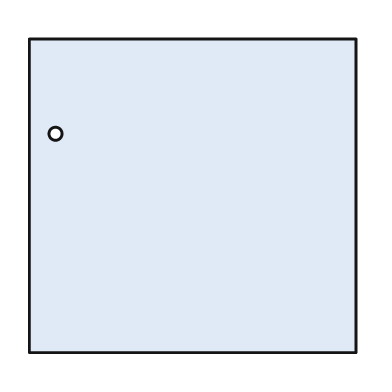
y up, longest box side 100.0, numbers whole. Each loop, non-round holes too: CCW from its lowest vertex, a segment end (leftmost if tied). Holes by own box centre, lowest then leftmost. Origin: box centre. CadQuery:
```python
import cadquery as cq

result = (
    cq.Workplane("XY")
    .moveTo(-50.0, -48.0)
    .lineTo(50.0, -48.0)
    .lineTo(50.0, 48.0)
    .lineTo(-50.0, 48.0)
    .close()
    .moveTo(-42.0, 19.0)
    .circle(2.0)
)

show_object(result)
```